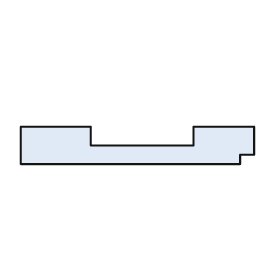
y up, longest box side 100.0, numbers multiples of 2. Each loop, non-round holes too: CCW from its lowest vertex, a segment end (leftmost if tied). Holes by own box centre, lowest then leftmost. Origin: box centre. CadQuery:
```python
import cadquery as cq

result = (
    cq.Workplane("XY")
    .moveTo(-50.0, -8.0)
    .lineTo(44.0, -8.0)
    .lineTo(44.0, -4.0)
    .lineTo(50.0, -4.0)
    .lineTo(50.0, 8.0)
    .lineTo(24.0, 8.0)
    .lineTo(24.0, 0.0)
    .lineTo(-20.0, 0.0)
    .lineTo(-20.0, 8.0)
    .lineTo(-50.0, 8.0)
    .close()
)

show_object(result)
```